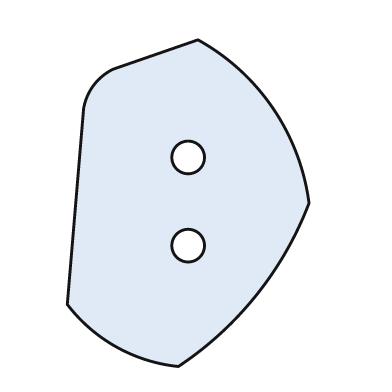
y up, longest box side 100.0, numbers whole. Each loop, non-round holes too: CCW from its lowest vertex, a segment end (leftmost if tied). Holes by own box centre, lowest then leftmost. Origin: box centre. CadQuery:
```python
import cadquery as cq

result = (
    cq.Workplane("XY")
    .moveTo(-3.0, -50.0)
    .threePointArc((21.0, -28.0), (37.0, 0.0))
    .threePointArc((26.0, 29.0), (3.0, 50.0))
    .lineTo(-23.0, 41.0)
    .threePointArc((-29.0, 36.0), (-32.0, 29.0))
    .lineTo(-37.0, -31.0)
    .threePointArc((-22.0, -44.0), (-3.0, -50.0))
    .close()
    .moveTo(0.0, -13.0)
    .circle(5.0)
    .moveTo(0.0, 14.0)
    .circle(5.0)
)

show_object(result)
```